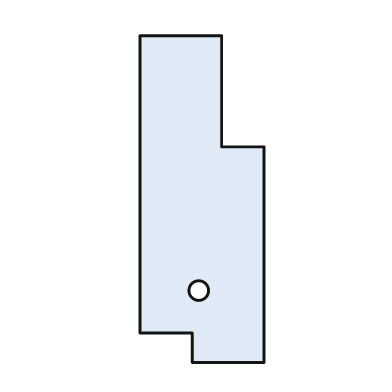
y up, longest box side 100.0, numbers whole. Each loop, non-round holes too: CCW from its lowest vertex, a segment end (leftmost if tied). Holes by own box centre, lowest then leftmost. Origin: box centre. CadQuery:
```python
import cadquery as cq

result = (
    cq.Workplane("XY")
    .moveTo(-3.0, -50.0)
    .lineTo(19.0, -50.0)
    .lineTo(19.0, 16.0)
    .lineTo(6.0, 16.0)
    .lineTo(6.0, 50.0)
    .lineTo(-19.0, 50.0)
    .lineTo(-19.0, -41.0)
    .lineTo(-3.0, -41.0)
    .close()
    .moveTo(-1.0, -28.0)
    .circle(3.0)
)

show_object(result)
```